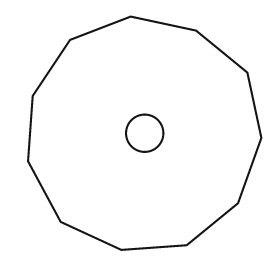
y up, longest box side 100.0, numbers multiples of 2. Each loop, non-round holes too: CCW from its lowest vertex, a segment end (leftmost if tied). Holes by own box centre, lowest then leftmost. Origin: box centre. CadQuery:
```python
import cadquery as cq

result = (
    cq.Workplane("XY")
    .moveTo(-10.0, -50.0)
    .lineTo(18.0, -48.0)
    .lineTo(40.0, -30.0)
    .lineTo(50.0, -2.0)
    .lineTo(44.0, 26.0)
    .lineTo(22.0, 44.0)
    .lineTo(-6.0, 50.0)
    .lineTo(-32.0, 40.0)
    .lineTo(-48.0, 16.0)
    .lineTo(-50.0, -12.0)
    .lineTo(-36.0, -38.0)
    .close()
    .moveTo(0.0, 0.0)
    .circle(8.0)
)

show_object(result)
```